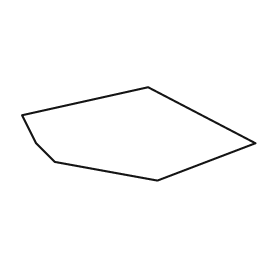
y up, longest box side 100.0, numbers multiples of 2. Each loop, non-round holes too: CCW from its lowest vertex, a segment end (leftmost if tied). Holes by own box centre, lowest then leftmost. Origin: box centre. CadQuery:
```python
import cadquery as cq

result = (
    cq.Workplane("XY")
    .moveTo(8.0, -20.0)
    .lineTo(50.0, -4.0)
    .lineTo(4.0, 20.0)
    .lineTo(-50.0, 8.0)
    .lineTo(-44.0, -4.0)
    .lineTo(-36.0, -12.0)
    .close()
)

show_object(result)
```